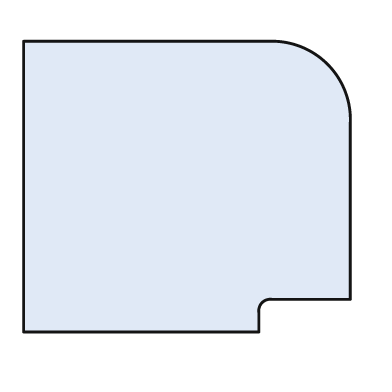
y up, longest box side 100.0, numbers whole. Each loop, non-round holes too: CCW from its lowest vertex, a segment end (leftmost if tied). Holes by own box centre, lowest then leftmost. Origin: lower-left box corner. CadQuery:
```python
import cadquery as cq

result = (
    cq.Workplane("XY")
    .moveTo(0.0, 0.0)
    .lineTo(72.0, 0.0)
    .lineTo(72.0, 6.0)
    .threePointArc((73.0, 9.0), (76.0, 10.0))
    .lineTo(100.0, 10.0)
    .lineTo(100.0, 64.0)
    .threePointArc((93.0, 82.0), (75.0, 89.0))
    .lineTo(0.0, 89.0)
    .close()
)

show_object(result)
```